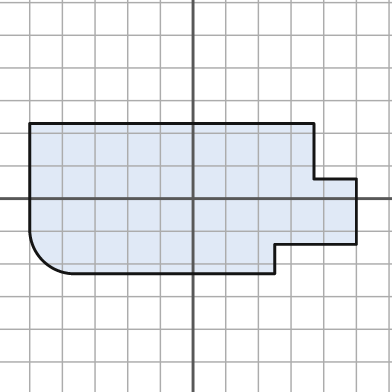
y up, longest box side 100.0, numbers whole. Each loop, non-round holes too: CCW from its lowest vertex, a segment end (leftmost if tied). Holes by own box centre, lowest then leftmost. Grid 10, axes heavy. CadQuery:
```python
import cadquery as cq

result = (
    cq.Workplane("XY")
    .moveTo(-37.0, -23.0)
    .lineTo(25.0, -23.0)
    .lineTo(25.0, -14.0)
    .lineTo(50.0, -14.0)
    .lineTo(50.0, 6.0)
    .lineTo(37.0, 6.0)
    .lineTo(37.0, 23.0)
    .lineTo(-50.0, 23.0)
    .lineTo(-50.0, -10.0)
    .threePointArc((-46.0, -19.0), (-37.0, -23.0))
    .close()
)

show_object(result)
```